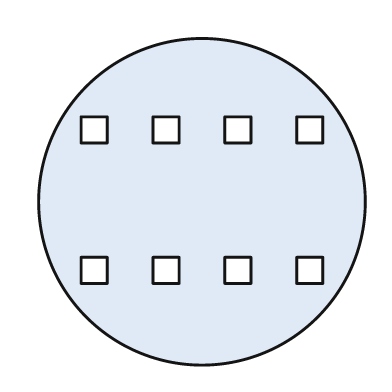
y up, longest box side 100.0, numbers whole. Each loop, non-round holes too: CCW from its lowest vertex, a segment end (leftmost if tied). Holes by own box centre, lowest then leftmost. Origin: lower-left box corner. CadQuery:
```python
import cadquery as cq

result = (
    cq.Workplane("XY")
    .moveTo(50.0, 50.0)
    .circle(50.0)
    .moveTo(13.0, 25.0)
    .lineTo(21.0, 25.0)
    .lineTo(21.0, 33.0)
    .lineTo(13.0, 33.0)
    .close()
    .moveTo(35.0, 25.0)
    .lineTo(43.0, 25.0)
    .lineTo(43.0, 33.0)
    .lineTo(35.0, 33.0)
    .close()
    .moveTo(57.0, 25.0)
    .lineTo(65.0, 25.0)
    .lineTo(65.0, 33.0)
    .lineTo(57.0, 33.0)
    .close()
    .moveTo(79.0, 25.0)
    .lineTo(87.0, 25.0)
    .lineTo(87.0, 33.0)
    .lineTo(79.0, 33.0)
    .close()
    .moveTo(13.0, 68.0)
    .lineTo(21.0, 68.0)
    .lineTo(21.0, 76.0)
    .lineTo(13.0, 76.0)
    .close()
    .moveTo(35.0, 68.0)
    .lineTo(43.0, 68.0)
    .lineTo(43.0, 76.0)
    .lineTo(35.0, 76.0)
    .close()
    .moveTo(57.0, 68.0)
    .lineTo(65.0, 68.0)
    .lineTo(65.0, 76.0)
    .lineTo(57.0, 76.0)
    .close()
    .moveTo(79.0, 68.0)
    .lineTo(87.0, 68.0)
    .lineTo(87.0, 76.0)
    .lineTo(79.0, 76.0)
    .close()
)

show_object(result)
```